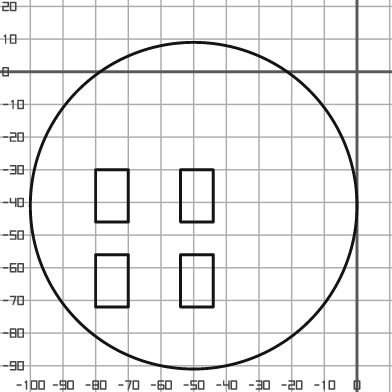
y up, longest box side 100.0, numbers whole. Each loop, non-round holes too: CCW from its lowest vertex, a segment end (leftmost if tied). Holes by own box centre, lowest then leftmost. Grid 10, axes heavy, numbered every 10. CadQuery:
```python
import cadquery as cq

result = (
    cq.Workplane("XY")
    .moveTo(-50.0, -41.0)
    .circle(50.0)
    .moveTo(-80.0, -72.0)
    .lineTo(-70.0, -72.0)
    .lineTo(-70.0, -56.0)
    .lineTo(-80.0, -56.0)
    .close()
    .moveTo(-54.0, -72.0)
    .lineTo(-44.0, -72.0)
    .lineTo(-44.0, -56.0)
    .lineTo(-54.0, -56.0)
    .close()
    .moveTo(-80.0, -46.0)
    .lineTo(-70.0, -46.0)
    .lineTo(-70.0, -30.0)
    .lineTo(-80.0, -30.0)
    .close()
    .moveTo(-54.0, -46.0)
    .lineTo(-44.0, -46.0)
    .lineTo(-44.0, -30.0)
    .lineTo(-54.0, -30.0)
    .close()
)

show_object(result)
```